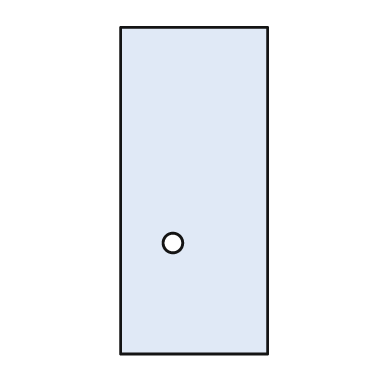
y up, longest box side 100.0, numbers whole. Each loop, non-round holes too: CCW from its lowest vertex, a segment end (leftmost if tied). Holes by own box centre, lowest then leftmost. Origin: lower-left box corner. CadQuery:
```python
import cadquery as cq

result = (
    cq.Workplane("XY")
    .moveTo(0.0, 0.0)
    .lineTo(45.0, 0.0)
    .lineTo(45.0, 100.0)
    .lineTo(0.0, 100.0)
    .close()
    .moveTo(16.0, 34.0)
    .circle(3.0)
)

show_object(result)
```